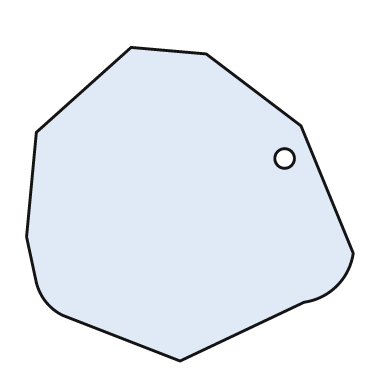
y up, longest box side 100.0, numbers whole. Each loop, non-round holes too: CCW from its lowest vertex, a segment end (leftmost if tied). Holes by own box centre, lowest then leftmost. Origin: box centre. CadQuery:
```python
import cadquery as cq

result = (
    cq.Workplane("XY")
    .moveTo(-3.0, -48.0)
    .lineTo(35.0, -30.0)
    .threePointArc((45.0, -25.0), (50.0, -15.0))
    .lineTo(34.0, 24.0)
    .lineTo(5.0, 46.0)
    .lineTo(-18.0, 48.0)
    .lineTo(-47.0, 22.0)
    .lineTo(-50.0, -10.0)
    .lineTo(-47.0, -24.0)
    .threePointArc((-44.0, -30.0), (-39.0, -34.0))
    .close()
    .moveTo(29.0, 14.0)
    .circle(3.0)
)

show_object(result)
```